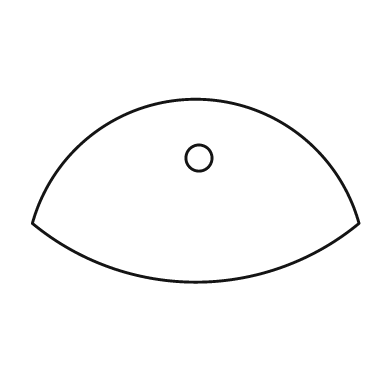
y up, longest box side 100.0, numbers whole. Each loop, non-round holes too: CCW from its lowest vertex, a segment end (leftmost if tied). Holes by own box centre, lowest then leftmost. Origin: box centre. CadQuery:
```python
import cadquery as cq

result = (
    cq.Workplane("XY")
    .moveTo(-50.0, -10.0)
    .threePointArc((0.0, -28.0), (50.0, -10.0))
    .threePointArc((0.0, 28.0), (-50.0, -10.0))
    .close()
    .moveTo(1.0, 10.0)
    .circle(4.0)
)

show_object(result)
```